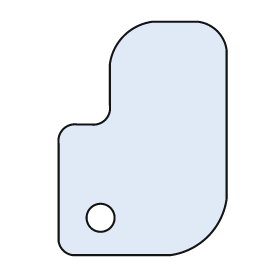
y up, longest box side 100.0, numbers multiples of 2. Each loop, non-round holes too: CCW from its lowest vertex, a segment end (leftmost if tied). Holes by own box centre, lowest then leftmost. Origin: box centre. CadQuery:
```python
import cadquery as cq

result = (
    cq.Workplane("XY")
    .moveTo(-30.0, -50.0)
    .lineTo(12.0, -50.0)
    .threePointArc((28.0, -42.0), (36.0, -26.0))
    .lineTo(36.0, 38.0)
    .threePointArc((32.0, 46.0), (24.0, 50.0))
    .lineTo(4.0, 50.0)
    .threePointArc((-8.0, 44.0), (-14.0, 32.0))
    .lineTo(-14.0, 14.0)
    .threePointArc((-16.0, 8.0), (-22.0, 6.0))
    .lineTo(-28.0, 6.0)
    .threePointArc((-34.0, 4.0), (-36.0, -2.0))
    .lineTo(-36.0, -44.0)
    .threePointArc((-34.0, -48.0), (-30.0, -50.0))
    .close()
    .moveTo(-18.0, -34.0)
    .circle(6.0)
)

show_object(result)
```